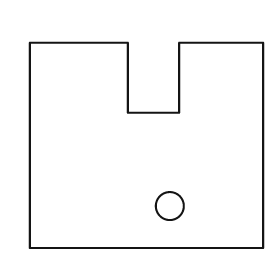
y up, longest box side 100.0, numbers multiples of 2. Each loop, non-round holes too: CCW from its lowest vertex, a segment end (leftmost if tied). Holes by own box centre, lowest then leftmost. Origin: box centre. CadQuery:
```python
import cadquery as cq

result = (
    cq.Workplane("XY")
    .moveTo(-50.0, -44.0)
    .lineTo(50.0, -44.0)
    .lineTo(50.0, 44.0)
    .lineTo(14.0, 44.0)
    .lineTo(14.0, 14.0)
    .lineTo(-8.0, 14.0)
    .lineTo(-8.0, 44.0)
    .lineTo(-50.0, 44.0)
    .close()
    .moveTo(10.0, -26.0)
    .circle(6.0)
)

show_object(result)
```